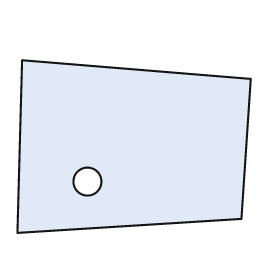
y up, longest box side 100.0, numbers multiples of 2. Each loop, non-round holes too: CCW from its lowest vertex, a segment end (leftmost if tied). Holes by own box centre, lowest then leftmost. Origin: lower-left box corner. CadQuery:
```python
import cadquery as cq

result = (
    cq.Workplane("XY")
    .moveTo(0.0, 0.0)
    .lineTo(96.0, 6.0)
    .lineTo(100.0, 66.0)
    .lineTo(2.0, 74.0)
    .close()
    .moveTo(30.0, 22.0)
    .circle(6.0)
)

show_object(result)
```